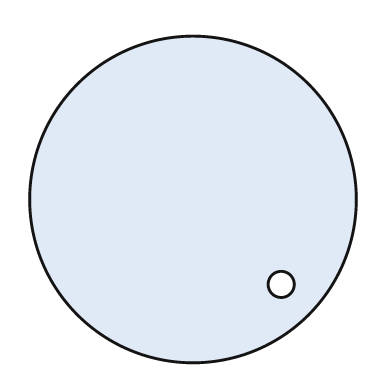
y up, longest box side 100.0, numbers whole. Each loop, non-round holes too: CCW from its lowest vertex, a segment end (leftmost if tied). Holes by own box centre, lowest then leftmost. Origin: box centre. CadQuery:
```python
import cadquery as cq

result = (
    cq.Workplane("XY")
    .moveTo(0.0, 0.0)
    .circle(50.0)
    .moveTo(27.0, -26.0)
    .circle(4.0)
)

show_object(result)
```